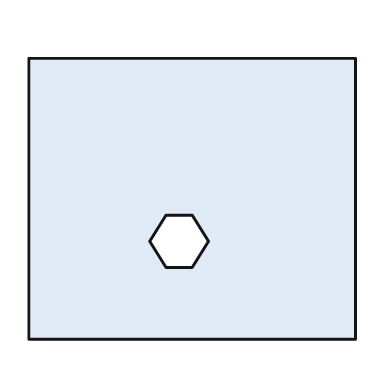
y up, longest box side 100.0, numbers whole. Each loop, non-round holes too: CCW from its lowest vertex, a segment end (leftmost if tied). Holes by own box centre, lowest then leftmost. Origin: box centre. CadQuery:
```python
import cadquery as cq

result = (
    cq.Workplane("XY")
    .moveTo(-50.0, -43.0)
    .lineTo(50.0, -43.0)
    .lineTo(50.0, 43.0)
    .lineTo(-50.0, 43.0)
    .close()
    .moveTo(-8.0, -21.0)
    .lineTo(0.0, -21.0)
    .lineTo(5.0, -13.0)
    .lineTo(0.0, -5.0)
    .lineTo(-8.0, -5.0)
    .lineTo(-13.0, -13.0)
    .close()
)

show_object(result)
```